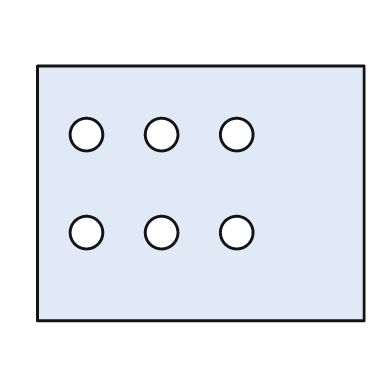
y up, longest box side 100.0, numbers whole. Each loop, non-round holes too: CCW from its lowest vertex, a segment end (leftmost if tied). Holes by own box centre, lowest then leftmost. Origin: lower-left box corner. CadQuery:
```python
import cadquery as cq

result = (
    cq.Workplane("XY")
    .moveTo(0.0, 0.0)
    .lineTo(100.0, 0.0)
    .lineTo(100.0, 78.0)
    .lineTo(0.0, 78.0)
    .close()
    .moveTo(15.0, 27.0)
    .circle(5.0)
    .moveTo(38.0, 27.0)
    .circle(5.0)
    .moveTo(61.0, 27.0)
    .circle(5.0)
    .moveTo(15.0, 57.0)
    .circle(5.0)
    .moveTo(38.0, 57.0)
    .circle(5.0)
    .moveTo(61.0, 57.0)
    .circle(5.0)
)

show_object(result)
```